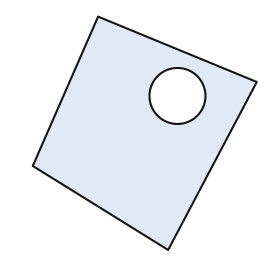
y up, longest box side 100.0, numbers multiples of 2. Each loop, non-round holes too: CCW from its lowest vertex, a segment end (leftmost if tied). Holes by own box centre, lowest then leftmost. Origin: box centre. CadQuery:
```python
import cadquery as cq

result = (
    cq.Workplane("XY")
    .moveTo(10.0, -50.0)
    .lineTo(48.0, 22.0)
    .lineTo(-20.0, 50.0)
    .lineTo(-48.0, -14.0)
    .close()
    .moveTo(14.0, 16.0)
    .circle(12.0)
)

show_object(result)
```